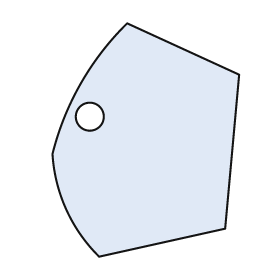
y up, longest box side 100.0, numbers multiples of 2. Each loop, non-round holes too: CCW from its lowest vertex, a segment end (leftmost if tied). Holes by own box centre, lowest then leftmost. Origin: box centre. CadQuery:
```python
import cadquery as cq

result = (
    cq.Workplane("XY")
    .moveTo(-20.0, -50.0)
    .lineTo(34.0, -38.0)
    .lineTo(40.0, 28.0)
    .lineTo(-8.0, 50.0)
    .threePointArc((-28.0, 24.0), (-40.0, -6.0))
    .threePointArc((-34.0, -30.0), (-20.0, -50.0))
    .close()
    .moveTo(-24.0, 10.0)
    .circle(6.0)
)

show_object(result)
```